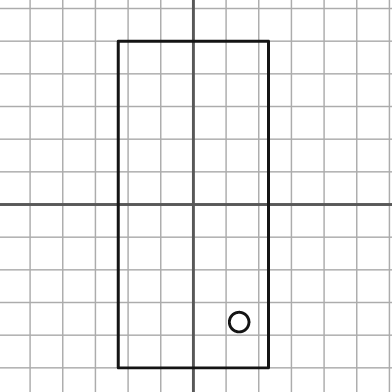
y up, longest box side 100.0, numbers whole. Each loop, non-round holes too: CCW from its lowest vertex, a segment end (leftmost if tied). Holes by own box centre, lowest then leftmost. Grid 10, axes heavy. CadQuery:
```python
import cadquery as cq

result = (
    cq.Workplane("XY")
    .moveTo(-23.0, -50.0)
    .lineTo(23.0, -50.0)
    .lineTo(23.0, 50.0)
    .lineTo(-23.0, 50.0)
    .close()
    .moveTo(14.0, -36.0)
    .circle(3.0)
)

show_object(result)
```